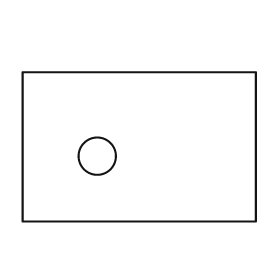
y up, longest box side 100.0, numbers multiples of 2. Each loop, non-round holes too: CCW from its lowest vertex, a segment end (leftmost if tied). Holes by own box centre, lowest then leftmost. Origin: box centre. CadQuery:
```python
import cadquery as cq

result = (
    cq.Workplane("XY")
    .moveTo(-50.0, -32.0)
    .lineTo(50.0, -32.0)
    .lineTo(50.0, 32.0)
    .lineTo(-50.0, 32.0)
    .close()
    .moveTo(-18.0, -4.0)
    .circle(8.0)
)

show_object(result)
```